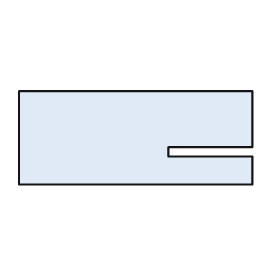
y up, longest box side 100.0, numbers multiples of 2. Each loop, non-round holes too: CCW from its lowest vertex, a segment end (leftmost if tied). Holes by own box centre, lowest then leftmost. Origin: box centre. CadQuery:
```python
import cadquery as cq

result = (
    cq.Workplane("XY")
    .moveTo(-50.0, -20.0)
    .lineTo(50.0, -20.0)
    .lineTo(50.0, -8.0)
    .lineTo(14.0, -8.0)
    .lineTo(14.0, -4.0)
    .lineTo(50.0, -4.0)
    .lineTo(50.0, 20.0)
    .lineTo(-50.0, 20.0)
    .close()
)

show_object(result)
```